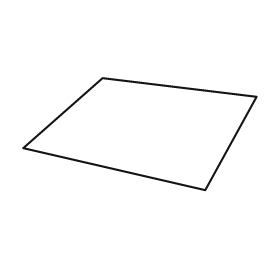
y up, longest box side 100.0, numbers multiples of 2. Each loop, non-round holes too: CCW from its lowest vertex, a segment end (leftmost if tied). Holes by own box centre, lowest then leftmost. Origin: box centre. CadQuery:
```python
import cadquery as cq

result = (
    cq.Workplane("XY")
    .moveTo(28.0, -24.0)
    .lineTo(50.0, 16.0)
    .lineTo(-16.0, 24.0)
    .lineTo(-50.0, -6.0)
    .close()
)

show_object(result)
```